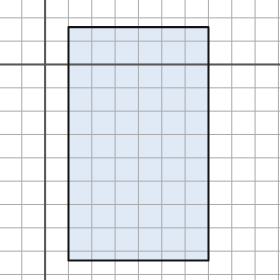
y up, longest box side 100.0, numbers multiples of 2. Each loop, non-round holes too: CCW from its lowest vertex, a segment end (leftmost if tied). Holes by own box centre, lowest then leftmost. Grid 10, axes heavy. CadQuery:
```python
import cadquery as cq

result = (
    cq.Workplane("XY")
    .moveTo(10.0, -84.0)
    .lineTo(70.0, -84.0)
    .lineTo(70.0, 16.0)
    .lineTo(10.0, 16.0)
    .close()
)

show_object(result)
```